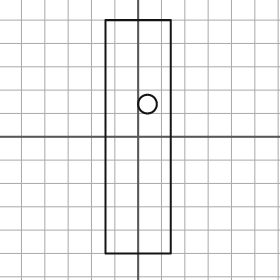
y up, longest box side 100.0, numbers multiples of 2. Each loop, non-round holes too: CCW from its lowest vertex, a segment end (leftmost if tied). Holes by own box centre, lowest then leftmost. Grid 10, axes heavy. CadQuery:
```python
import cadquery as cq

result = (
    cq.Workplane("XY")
    .moveTo(-14.0, -50.0)
    .lineTo(14.0, -50.0)
    .lineTo(14.0, 50.0)
    .lineTo(-14.0, 50.0)
    .close()
    .moveTo(4.0, 14.0)
    .circle(4.0)
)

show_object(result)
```